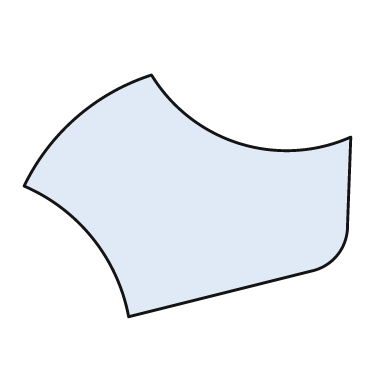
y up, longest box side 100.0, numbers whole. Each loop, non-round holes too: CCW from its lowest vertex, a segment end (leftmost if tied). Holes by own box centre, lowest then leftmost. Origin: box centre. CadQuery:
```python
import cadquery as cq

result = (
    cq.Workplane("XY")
    .moveTo(-18.0, -37.0)
    .lineTo(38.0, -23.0)
    .threePointArc((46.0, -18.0), (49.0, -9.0))
    .lineTo(50.0, 18.0)
    .threePointArc((16.0, 16.0), (-11.0, 37.0))
    .threePointArc((-34.0, 24.0), (-50.0, 3.0))
    .threePointArc((-29.0, -13.0), (-18.0, -37.0))
    .close()
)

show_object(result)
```